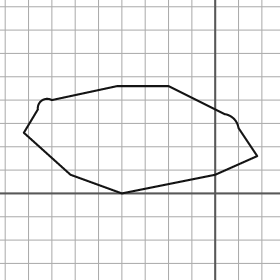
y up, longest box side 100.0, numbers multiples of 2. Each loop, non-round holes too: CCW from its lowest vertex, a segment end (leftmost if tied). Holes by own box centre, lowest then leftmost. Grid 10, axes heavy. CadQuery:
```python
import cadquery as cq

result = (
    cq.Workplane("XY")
    .moveTo(-40.0, 0.0)
    .lineTo(0.0, 8.0)
    .lineTo(18.0, 16.0)
    .lineTo(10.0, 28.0)
    .threePointArc((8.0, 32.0), (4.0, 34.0))
    .lineTo(-20.0, 46.0)
    .lineTo(-42.0, 46.0)
    .lineTo(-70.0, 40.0)
    .threePointArc((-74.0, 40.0), (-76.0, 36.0))
    .lineTo(-82.0, 26.0)
    .lineTo(-62.0, 8.0)
    .close()
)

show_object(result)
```